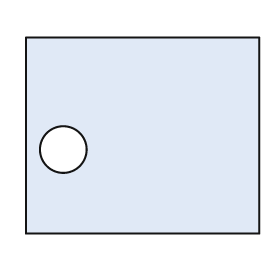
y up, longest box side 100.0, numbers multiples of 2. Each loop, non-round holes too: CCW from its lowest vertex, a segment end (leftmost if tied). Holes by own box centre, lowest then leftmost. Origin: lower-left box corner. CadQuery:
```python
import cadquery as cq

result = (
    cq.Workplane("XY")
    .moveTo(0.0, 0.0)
    .lineTo(100.0, 0.0)
    .lineTo(100.0, 84.0)
    .lineTo(0.0, 84.0)
    .close()
    .moveTo(16.0, 36.0)
    .circle(10.0)
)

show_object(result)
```